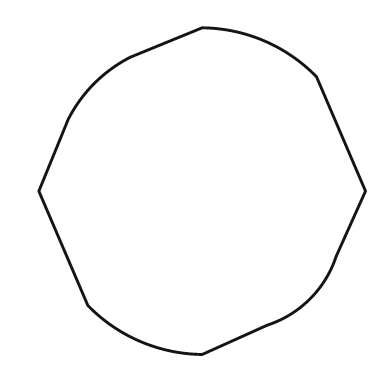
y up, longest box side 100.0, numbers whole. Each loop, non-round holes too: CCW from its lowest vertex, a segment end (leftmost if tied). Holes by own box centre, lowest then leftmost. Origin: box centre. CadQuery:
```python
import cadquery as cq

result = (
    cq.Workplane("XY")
    .moveTo(0.0, -50.0)
    .lineTo(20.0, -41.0)
    .threePointArc((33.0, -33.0), (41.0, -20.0))
    .lineTo(50.0, 0.0)
    .lineTo(35.0, 35.0)
    .threePointArc((19.0, 46.0), (0.0, 50.0))
    .lineTo(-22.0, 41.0)
    .threePointArc((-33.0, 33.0), (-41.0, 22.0))
    .lineTo(-50.0, 0.0)
    .lineTo(-35.0, -35.0)
    .threePointArc((-19.0, -46.0), (0.0, -50.0))
    .close()
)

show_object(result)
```